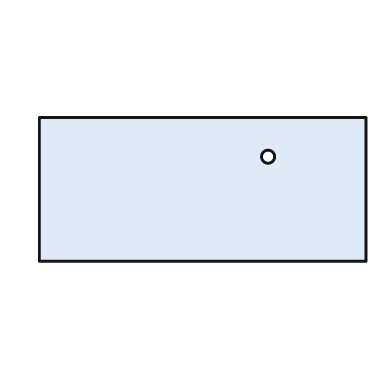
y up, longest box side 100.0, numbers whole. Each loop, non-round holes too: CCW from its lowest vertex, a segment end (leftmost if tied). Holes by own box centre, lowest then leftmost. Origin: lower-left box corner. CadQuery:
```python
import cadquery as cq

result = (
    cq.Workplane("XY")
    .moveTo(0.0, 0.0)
    .lineTo(100.0, 0.0)
    .lineTo(100.0, 44.0)
    .lineTo(0.0, 44.0)
    .close()
    .moveTo(70.0, 32.0)
    .circle(2.0)
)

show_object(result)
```